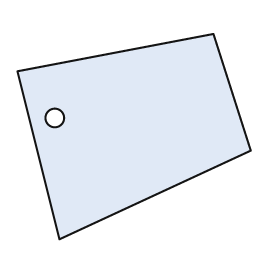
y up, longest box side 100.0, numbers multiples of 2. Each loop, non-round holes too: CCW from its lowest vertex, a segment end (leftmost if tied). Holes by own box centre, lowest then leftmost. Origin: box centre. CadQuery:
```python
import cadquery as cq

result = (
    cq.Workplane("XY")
    .moveTo(-32.0, -44.0)
    .lineTo(50.0, -6.0)
    .lineTo(34.0, 44.0)
    .lineTo(-50.0, 28.0)
    .close()
    .moveTo(-34.0, 8.0)
    .circle(4.0)
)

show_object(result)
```